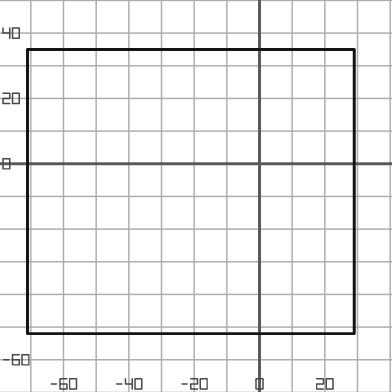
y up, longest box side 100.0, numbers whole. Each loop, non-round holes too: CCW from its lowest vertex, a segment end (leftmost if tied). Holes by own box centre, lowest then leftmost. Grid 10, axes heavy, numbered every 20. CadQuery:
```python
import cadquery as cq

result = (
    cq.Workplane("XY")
    .moveTo(-71.0, -52.0)
    .lineTo(29.0, -52.0)
    .lineTo(29.0, 35.0)
    .lineTo(-71.0, 35.0)
    .close()
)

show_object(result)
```